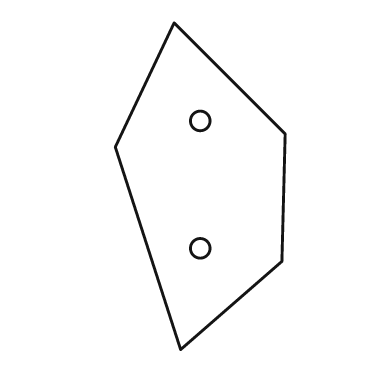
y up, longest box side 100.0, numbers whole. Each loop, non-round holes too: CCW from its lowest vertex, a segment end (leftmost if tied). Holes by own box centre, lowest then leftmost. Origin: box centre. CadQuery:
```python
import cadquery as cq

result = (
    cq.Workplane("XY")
    .moveTo(-6.0, -50.0)
    .lineTo(25.0, -23.0)
    .lineTo(26.0, 16.0)
    .lineTo(-8.0, 50.0)
    .lineTo(-26.0, 12.0)
    .close()
    .moveTo(0.0, -19.0)
    .circle(3.0)
    .moveTo(0.0, 20.0)
    .circle(3.0)
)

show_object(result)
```